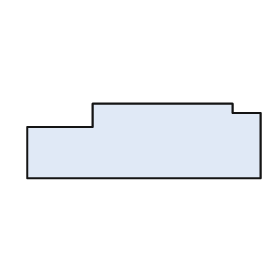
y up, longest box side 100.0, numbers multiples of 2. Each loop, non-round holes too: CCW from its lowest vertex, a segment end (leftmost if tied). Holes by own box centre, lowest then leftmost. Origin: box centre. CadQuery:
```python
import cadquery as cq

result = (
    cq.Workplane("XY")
    .moveTo(-50.0, -16.0)
    .lineTo(50.0, -16.0)
    .lineTo(50.0, 12.0)
    .lineTo(38.0, 12.0)
    .lineTo(38.0, 16.0)
    .lineTo(-22.0, 16.0)
    .lineTo(-22.0, 6.0)
    .lineTo(-50.0, 6.0)
    .close()
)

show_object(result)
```